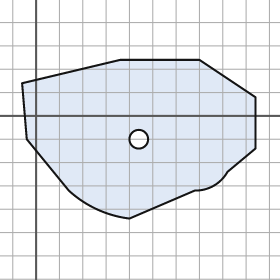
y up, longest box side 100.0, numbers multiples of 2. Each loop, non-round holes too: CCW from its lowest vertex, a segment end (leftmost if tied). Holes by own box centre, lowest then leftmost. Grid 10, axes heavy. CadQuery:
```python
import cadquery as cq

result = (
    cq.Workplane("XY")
    .moveTo(40.0, -44.0)
    .lineTo(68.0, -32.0)
    .threePointArc((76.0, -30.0), (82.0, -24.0))
    .lineTo(94.0, -14.0)
    .lineTo(94.0, 8.0)
    .lineTo(70.0, 24.0)
    .lineTo(36.0, 24.0)
    .lineTo(-6.0, 14.0)
    .lineTo(-4.0, -10.0)
    .lineTo(14.0, -32.0)
    .threePointArc((26.0, -40.0), (40.0, -44.0))
    .close()
    .moveTo(44.0, -10.0)
    .circle(4.0)
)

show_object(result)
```